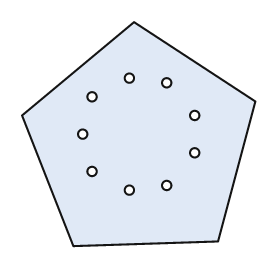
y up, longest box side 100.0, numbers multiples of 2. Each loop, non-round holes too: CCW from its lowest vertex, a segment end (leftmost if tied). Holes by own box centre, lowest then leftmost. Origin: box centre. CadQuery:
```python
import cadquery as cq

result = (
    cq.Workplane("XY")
    .moveTo(-28.0, -48.0)
    .lineTo(34.0, -46.0)
    .lineTo(50.0, 14.0)
    .lineTo(-2.0, 48.0)
    .lineTo(-50.0, 8.0)
    .close()
    .moveTo(-4.0, -24.0)
    .circle(2.0)
    .moveTo(12.0, -22.0)
    .circle(2.0)
    .moveTo(-20.0, -16.0)
    .circle(2.0)
    .moveTo(24.0, -8.0)
    .circle(2.0)
    .moveTo(-24.0, 0.0)
    .circle(2.0)
    .moveTo(24.0, 8.0)
    .circle(2.0)
    .moveTo(-20.0, 16.0)
    .circle(2.0)
    .moveTo(12.0, 22.0)
    .circle(2.0)
    .moveTo(-4.0, 24.0)
    .circle(2.0)
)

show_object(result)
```